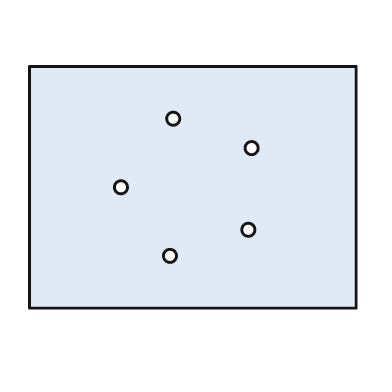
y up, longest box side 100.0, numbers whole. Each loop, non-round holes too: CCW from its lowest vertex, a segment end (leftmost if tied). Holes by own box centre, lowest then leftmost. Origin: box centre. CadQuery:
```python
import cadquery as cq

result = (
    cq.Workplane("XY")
    .moveTo(-50.0, -37.0)
    .lineTo(50.0, -37.0)
    .lineTo(50.0, 37.0)
    .lineTo(-50.0, 37.0)
    .close()
    .moveTo(-7.0, -21.0)
    .circle(2.0)
    .moveTo(17.0, -13.0)
    .circle(2.0)
    .moveTo(-22.0, 0.0)
    .circle(2.0)
    .moveTo(18.0, 12.0)
    .circle(2.0)
    .moveTo(-6.0, 21.0)
    .circle(2.0)
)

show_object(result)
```